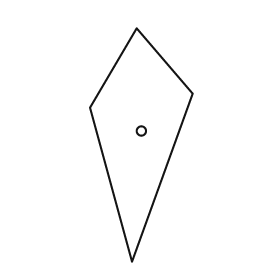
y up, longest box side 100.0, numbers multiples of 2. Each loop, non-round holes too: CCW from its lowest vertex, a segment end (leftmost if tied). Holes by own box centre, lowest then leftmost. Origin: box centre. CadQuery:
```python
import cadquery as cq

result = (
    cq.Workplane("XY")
    .moveTo(-4.0, -50.0)
    .lineTo(22.0, 22.0)
    .lineTo(-2.0, 50.0)
    .lineTo(-22.0, 16.0)
    .close()
    .moveTo(0.0, 6.0)
    .circle(2.0)
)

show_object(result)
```